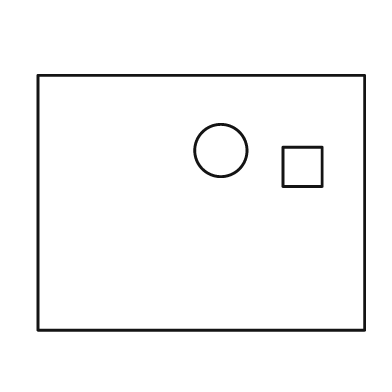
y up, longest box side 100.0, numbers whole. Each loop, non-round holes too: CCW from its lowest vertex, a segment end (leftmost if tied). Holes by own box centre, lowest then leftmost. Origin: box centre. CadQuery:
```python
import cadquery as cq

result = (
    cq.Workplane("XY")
    .moveTo(-50.0, -39.0)
    .lineTo(50.0, -39.0)
    .lineTo(50.0, 39.0)
    .lineTo(-50.0, 39.0)
    .close()
    .moveTo(25.0, 5.0)
    .lineTo(37.0, 5.0)
    .lineTo(37.0, 17.0)
    .lineTo(25.0, 17.0)
    .close()
    .moveTo(6.0, 16.0)
    .circle(8.0)
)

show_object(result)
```